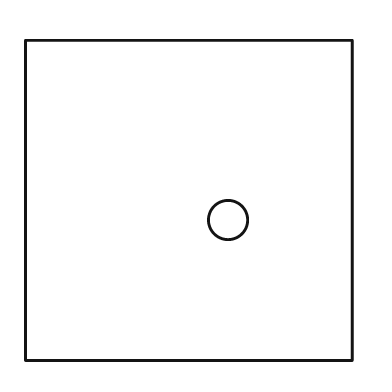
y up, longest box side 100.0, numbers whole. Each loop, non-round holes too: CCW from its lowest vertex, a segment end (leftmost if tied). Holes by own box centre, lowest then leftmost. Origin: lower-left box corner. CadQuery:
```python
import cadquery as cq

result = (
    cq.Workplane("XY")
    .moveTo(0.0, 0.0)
    .lineTo(100.0, 0.0)
    .lineTo(100.0, 98.0)
    .lineTo(0.0, 98.0)
    .close()
    .moveTo(62.0, 43.0)
    .circle(6.0)
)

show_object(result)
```